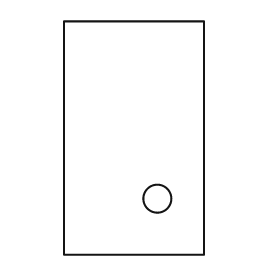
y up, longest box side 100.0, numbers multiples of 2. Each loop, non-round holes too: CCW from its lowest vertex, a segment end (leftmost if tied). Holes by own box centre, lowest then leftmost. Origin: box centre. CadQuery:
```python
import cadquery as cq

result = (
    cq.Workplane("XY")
    .moveTo(-30.0, -50.0)
    .lineTo(30.0, -50.0)
    .lineTo(30.0, 50.0)
    .lineTo(-30.0, 50.0)
    .close()
    .moveTo(10.0, -26.0)
    .circle(6.0)
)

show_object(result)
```